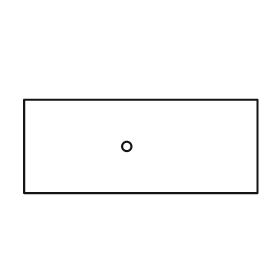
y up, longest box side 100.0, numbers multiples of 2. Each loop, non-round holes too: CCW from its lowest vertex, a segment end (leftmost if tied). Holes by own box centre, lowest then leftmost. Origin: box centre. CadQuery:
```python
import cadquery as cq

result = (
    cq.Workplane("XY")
    .moveTo(-50.0, -20.0)
    .lineTo(50.0, -20.0)
    .lineTo(50.0, 20.0)
    .lineTo(-50.0, 20.0)
    .close()
    .moveTo(-6.0, 0.0)
    .circle(2.0)
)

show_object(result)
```